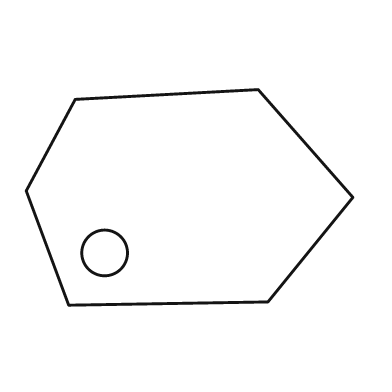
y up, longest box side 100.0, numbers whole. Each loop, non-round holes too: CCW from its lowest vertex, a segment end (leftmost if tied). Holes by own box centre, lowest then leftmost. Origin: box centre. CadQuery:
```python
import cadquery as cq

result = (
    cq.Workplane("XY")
    .moveTo(-37.0, -33.0)
    .lineTo(24.0, -32.0)
    .lineTo(50.0, 0.0)
    .lineTo(21.0, 33.0)
    .lineTo(-35.0, 30.0)
    .lineTo(-50.0, 2.0)
    .close()
    .moveTo(-26.0, -17.0)
    .circle(7.0)
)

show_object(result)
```